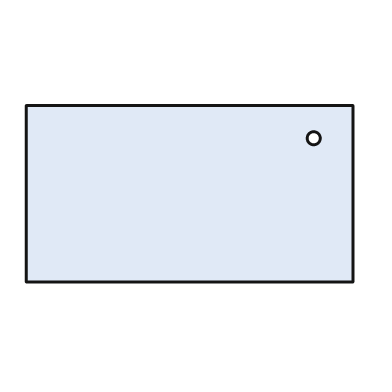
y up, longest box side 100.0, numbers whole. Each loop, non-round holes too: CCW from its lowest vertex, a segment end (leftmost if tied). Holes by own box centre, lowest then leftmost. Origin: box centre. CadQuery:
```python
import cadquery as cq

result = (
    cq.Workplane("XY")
    .moveTo(-50.0, -27.0)
    .lineTo(50.0, -27.0)
    .lineTo(50.0, 27.0)
    .lineTo(-50.0, 27.0)
    .close()
    .moveTo(38.0, 17.0)
    .circle(2.0)
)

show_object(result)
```